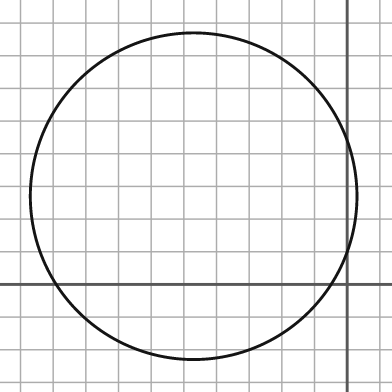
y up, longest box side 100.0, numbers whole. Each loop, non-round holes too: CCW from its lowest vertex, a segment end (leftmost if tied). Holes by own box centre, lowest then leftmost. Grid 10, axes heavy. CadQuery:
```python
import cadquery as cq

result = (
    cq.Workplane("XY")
    .moveTo(-47.0, 27.0)
    .circle(50.0)
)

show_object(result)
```